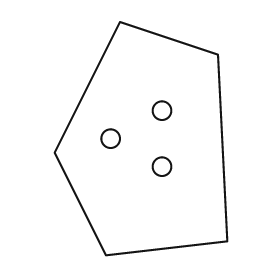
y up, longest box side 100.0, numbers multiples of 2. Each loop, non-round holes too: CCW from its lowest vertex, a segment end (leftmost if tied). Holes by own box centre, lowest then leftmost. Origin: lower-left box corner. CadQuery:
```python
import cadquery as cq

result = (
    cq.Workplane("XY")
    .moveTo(22.0, 0.0)
    .lineTo(74.0, 6.0)
    .lineTo(70.0, 86.0)
    .lineTo(28.0, 100.0)
    .lineTo(0.0, 44.0)
    .close()
    .moveTo(46.0, 38.0)
    .circle(4.0)
    .moveTo(24.0, 50.0)
    .circle(4.0)
    .moveTo(46.0, 62.0)
    .circle(4.0)
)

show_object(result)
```